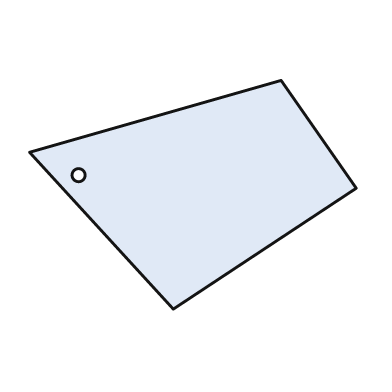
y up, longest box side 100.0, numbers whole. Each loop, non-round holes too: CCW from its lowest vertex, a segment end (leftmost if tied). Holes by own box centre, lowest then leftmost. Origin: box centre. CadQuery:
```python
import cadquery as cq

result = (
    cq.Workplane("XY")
    .moveTo(-6.0, -35.0)
    .lineTo(50.0, 2.0)
    .lineTo(27.0, 35.0)
    .lineTo(-50.0, 13.0)
    .close()
    .moveTo(-35.0, 6.0)
    .circle(2.0)
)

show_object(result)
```